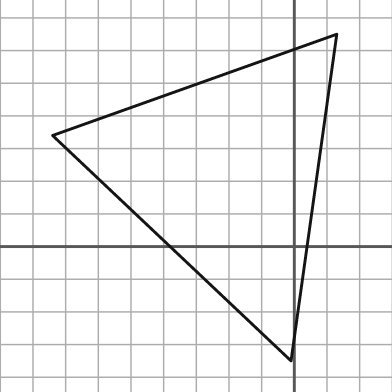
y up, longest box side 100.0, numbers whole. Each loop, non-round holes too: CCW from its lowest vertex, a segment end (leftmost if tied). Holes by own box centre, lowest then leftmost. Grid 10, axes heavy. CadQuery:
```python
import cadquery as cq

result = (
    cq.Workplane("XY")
    .moveTo(-1.0, -35.0)
    .lineTo(13.0, 65.0)
    .lineTo(-74.0, 34.0)
    .close()
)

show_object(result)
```